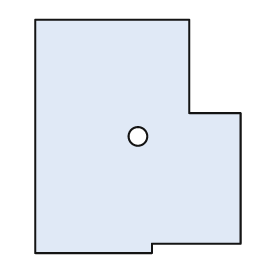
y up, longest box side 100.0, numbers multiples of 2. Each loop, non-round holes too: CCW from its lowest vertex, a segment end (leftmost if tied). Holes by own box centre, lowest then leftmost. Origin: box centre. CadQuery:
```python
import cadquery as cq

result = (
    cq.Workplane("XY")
    .moveTo(-44.0, -50.0)
    .lineTo(6.0, -50.0)
    .lineTo(6.0, -46.0)
    .lineTo(44.0, -46.0)
    .lineTo(44.0, 10.0)
    .lineTo(22.0, 10.0)
    .lineTo(22.0, 50.0)
    .lineTo(-44.0, 50.0)
    .close()
    .moveTo(0.0, 0.0)
    .circle(4.0)
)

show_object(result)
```